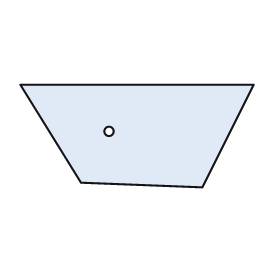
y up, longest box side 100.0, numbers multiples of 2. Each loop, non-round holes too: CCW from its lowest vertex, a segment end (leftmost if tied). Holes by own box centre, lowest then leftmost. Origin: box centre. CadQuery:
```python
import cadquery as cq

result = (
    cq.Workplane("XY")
    .moveTo(28.0, -22.0)
    .lineTo(50.0, 22.0)
    .lineTo(-50.0, 22.0)
    .lineTo(-24.0, -20.0)
    .close()
    .moveTo(-12.0, 2.0)
    .circle(2.0)
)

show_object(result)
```